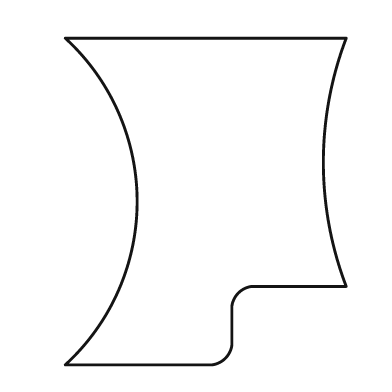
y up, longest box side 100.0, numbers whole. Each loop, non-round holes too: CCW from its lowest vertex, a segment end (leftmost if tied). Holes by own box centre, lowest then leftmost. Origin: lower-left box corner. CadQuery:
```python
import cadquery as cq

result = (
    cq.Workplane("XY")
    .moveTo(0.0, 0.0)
    .lineTo(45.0, 0.0)
    .threePointArc((49.0, 2.0), (51.0, 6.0))
    .lineTo(51.0, 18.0)
    .threePointArc((53.0, 22.0), (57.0, 24.0))
    .lineTo(86.0, 24.0)
    .threePointArc((79.0, 62.0), (86.0, 100.0))
    .lineTo(0.0, 100.0)
    .threePointArc((22.0, 50.0), (0.0, 0.0))
    .close()
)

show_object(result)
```